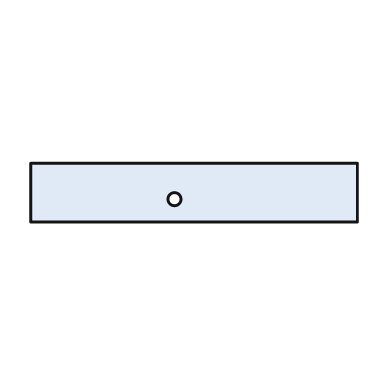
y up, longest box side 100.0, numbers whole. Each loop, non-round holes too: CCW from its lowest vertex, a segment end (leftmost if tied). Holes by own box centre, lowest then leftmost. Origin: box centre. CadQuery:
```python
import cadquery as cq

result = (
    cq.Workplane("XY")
    .moveTo(-50.0, -9.0)
    .lineTo(50.0, -9.0)
    .lineTo(50.0, 9.0)
    .lineTo(-50.0, 9.0)
    .close()
    .moveTo(-6.0, -2.0)
    .circle(2.0)
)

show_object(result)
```